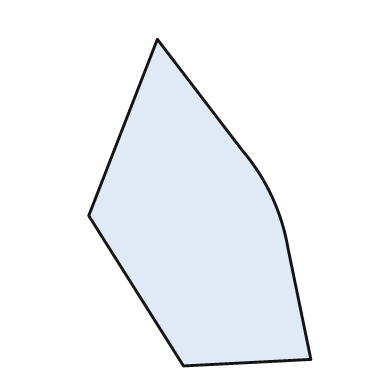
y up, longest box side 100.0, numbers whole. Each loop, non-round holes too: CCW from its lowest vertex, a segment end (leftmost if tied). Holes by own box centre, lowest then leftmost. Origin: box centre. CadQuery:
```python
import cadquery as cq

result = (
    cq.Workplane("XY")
    .moveTo(-5.0, -50.0)
    .lineTo(34.0, -48.0)
    .lineTo(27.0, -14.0)
    .threePointArc((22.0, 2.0), (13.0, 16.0))
    .lineTo(-13.0, 50.0)
    .lineTo(-34.0, -4.0)
    .close()
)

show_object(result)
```